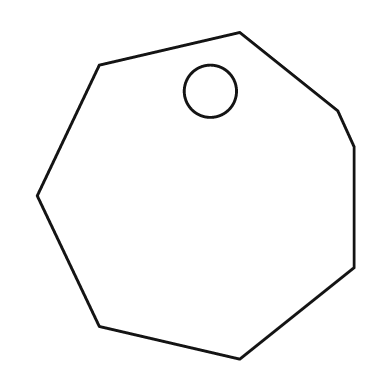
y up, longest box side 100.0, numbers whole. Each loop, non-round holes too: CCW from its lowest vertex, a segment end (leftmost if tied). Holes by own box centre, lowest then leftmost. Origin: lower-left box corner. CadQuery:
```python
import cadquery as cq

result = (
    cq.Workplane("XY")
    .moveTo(62.0, 0.0)
    .lineTo(97.0, 28.0)
    .lineTo(97.0, 65.0)
    .lineTo(92.0, 76.0)
    .lineTo(62.0, 100.0)
    .lineTo(19.0, 90.0)
    .lineTo(0.0, 50.0)
    .lineTo(19.0, 10.0)
    .close()
    .moveTo(53.0, 82.0)
    .circle(8.0)
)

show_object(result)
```